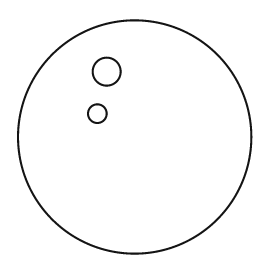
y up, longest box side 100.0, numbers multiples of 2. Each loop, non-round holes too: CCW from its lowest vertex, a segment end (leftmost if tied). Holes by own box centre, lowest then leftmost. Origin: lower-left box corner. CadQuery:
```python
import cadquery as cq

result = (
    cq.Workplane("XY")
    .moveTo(50.0, 50.0)
    .circle(50.0)
    .moveTo(34.0, 60.0)
    .circle(4.0)
    .moveTo(38.0, 78.0)
    .circle(6.0)
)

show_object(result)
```